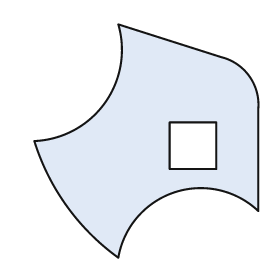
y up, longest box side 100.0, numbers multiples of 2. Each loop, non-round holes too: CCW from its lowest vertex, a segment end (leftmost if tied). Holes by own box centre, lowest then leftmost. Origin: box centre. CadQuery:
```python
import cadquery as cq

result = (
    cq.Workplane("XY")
    .moveTo(-12.0, -50.0)
    .threePointArc((12.0, -22.0), (48.0, -30.0))
    .lineTo(48.0, 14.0)
    .threePointArc((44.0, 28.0), (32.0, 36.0))
    .lineTo(-12.0, 50.0)
    .threePointArc((-18.0, 16.0), (-48.0, 0.0))
    .threePointArc((-34.0, -28.0), (-12.0, -50.0))
    .close()
    .moveTo(10.0, -12.0)
    .lineTo(30.0, -12.0)
    .lineTo(30.0, 8.0)
    .lineTo(10.0, 8.0)
    .close()
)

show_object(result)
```